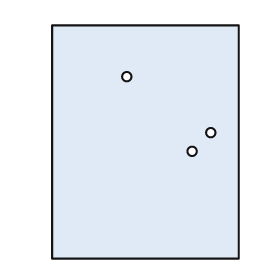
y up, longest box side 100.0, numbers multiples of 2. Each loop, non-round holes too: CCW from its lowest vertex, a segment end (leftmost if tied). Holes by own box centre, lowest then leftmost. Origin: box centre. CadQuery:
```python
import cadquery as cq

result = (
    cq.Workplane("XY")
    .moveTo(-40.0, -50.0)
    .lineTo(40.0, -50.0)
    .lineTo(40.0, 50.0)
    .lineTo(-40.0, 50.0)
    .close()
    .moveTo(20.0, -4.0)
    .circle(2.0)
    .moveTo(28.0, 4.0)
    .circle(2.0)
    .moveTo(-8.0, 28.0)
    .circle(2.0)
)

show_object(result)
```